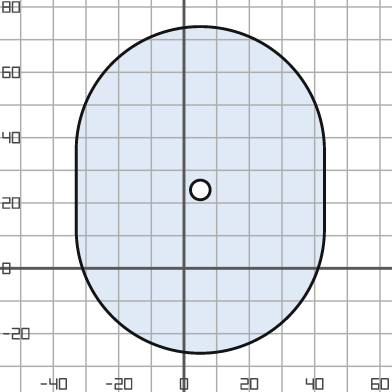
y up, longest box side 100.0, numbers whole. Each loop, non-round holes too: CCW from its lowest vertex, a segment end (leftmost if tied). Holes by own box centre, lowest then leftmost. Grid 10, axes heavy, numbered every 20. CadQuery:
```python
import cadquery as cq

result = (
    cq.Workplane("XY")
    .moveTo(-33.0, 12.0)
    .threePointArc((5.0, -26.0), (43.0, 12.0))
    .lineTo(43.0, 36.0)
    .threePointArc((5.0, 74.0), (-33.0, 36.0))
    .close()
    .moveTo(5.0, 24.0)
    .circle(3.0)
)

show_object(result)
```